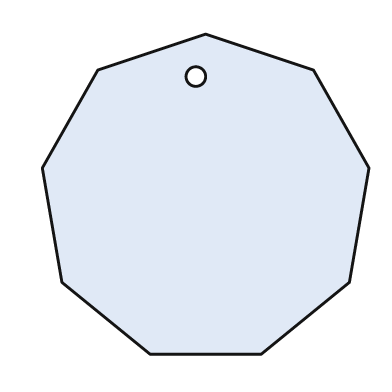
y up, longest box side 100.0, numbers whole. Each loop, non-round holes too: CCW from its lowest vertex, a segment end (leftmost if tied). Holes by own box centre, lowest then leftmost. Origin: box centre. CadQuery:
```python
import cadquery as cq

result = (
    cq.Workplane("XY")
    .moveTo(-17.0, -49.0)
    .lineTo(17.0, -49.0)
    .lineTo(44.0, -27.0)
    .lineTo(50.0, 8.0)
    .lineTo(33.0, 38.0)
    .lineTo(0.0, 49.0)
    .lineTo(-33.0, 38.0)
    .lineTo(-50.0, 8.0)
    .lineTo(-44.0, -27.0)
    .close()
    .moveTo(-3.0, 36.0)
    .circle(3.0)
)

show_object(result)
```